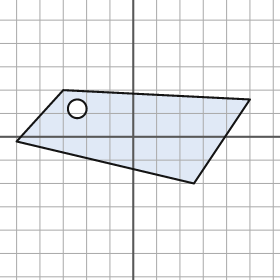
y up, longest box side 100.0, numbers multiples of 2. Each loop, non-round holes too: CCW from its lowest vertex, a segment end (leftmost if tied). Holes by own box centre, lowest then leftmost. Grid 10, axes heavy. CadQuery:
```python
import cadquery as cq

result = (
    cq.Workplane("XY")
    .moveTo(26.0, -20.0)
    .lineTo(50.0, 16.0)
    .lineTo(-30.0, 20.0)
    .lineTo(-50.0, -2.0)
    .close()
    .moveTo(-24.0, 12.0)
    .circle(4.0)
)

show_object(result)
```